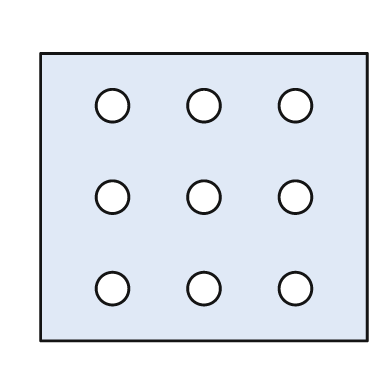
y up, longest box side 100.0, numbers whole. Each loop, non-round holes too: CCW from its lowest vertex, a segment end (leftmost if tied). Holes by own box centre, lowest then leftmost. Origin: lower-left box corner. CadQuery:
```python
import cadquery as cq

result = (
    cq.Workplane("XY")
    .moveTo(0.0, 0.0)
    .lineTo(100.0, 0.0)
    .lineTo(100.0, 88.0)
    .lineTo(0.0, 88.0)
    .close()
    .moveTo(22.0, 16.0)
    .circle(5.0)
    .moveTo(50.0, 16.0)
    .circle(5.0)
    .moveTo(78.0, 16.0)
    .circle(5.0)
    .moveTo(22.0, 44.0)
    .circle(5.0)
    .moveTo(50.0, 44.0)
    .circle(5.0)
    .moveTo(78.0, 44.0)
    .circle(5.0)
    .moveTo(22.0, 72.0)
    .circle(5.0)
    .moveTo(50.0, 72.0)
    .circle(5.0)
    .moveTo(78.0, 72.0)
    .circle(5.0)
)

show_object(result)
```